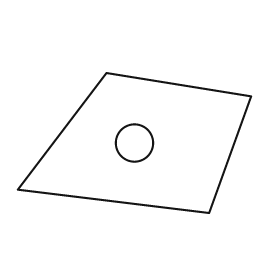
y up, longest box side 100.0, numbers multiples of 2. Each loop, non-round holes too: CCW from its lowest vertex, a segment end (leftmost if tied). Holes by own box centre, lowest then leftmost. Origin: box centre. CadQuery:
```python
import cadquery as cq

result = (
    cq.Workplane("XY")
    .moveTo(32.0, -30.0)
    .lineTo(50.0, 20.0)
    .lineTo(-12.0, 30.0)
    .lineTo(-50.0, -20.0)
    .close()
    .moveTo(0.0, 0.0)
    .circle(8.0)
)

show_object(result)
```